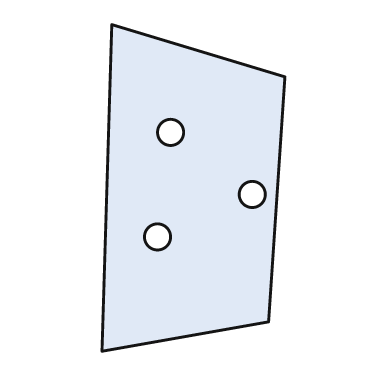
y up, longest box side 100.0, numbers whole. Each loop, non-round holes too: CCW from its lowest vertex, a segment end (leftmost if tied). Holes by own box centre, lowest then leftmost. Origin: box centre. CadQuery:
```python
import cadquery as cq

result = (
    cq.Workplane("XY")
    .moveTo(-28.0, -50.0)
    .lineTo(23.0, -41.0)
    .lineTo(28.0, 34.0)
    .lineTo(-25.0, 50.0)
    .close()
    .moveTo(-11.0, -15.0)
    .circle(4.0)
    .moveTo(18.0, -2.0)
    .circle(4.0)
    .moveTo(-7.0, 17.0)
    .circle(4.0)
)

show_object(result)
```